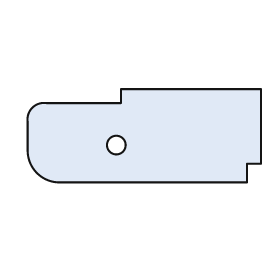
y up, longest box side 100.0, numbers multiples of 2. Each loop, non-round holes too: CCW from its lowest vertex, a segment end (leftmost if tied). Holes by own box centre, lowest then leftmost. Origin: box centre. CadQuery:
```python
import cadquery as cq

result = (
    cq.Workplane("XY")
    .moveTo(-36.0, -20.0)
    .lineTo(44.0, -20.0)
    .lineTo(44.0, -12.0)
    .lineTo(50.0, -12.0)
    .lineTo(50.0, 20.0)
    .lineTo(-10.0, 20.0)
    .lineTo(-10.0, 14.0)
    .lineTo(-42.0, 14.0)
    .threePointArc((-48.0, 12.0), (-50.0, 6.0))
    .lineTo(-50.0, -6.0)
    .threePointArc((-46.0, -16.0), (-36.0, -20.0))
    .close()
    .moveTo(-12.0, -4.0)
    .circle(4.0)
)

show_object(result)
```